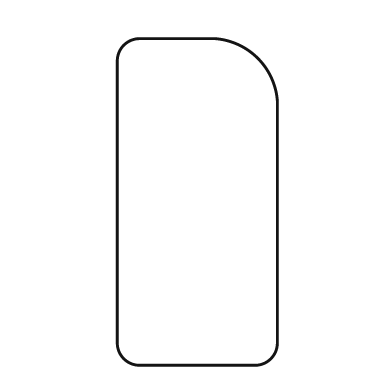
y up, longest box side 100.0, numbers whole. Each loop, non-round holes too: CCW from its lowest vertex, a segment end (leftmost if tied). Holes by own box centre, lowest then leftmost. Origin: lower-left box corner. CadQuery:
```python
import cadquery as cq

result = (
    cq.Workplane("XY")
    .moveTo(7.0, 0.0)
    .lineTo(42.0, 0.0)
    .threePointArc((47.0, 2.0), (49.0, 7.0))
    .lineTo(49.0, 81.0)
    .threePointArc((43.0, 94.0), (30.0, 100.0))
    .lineTo(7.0, 100.0)
    .threePointArc((2.0, 98.0), (0.0, 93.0))
    .lineTo(0.0, 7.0)
    .threePointArc((2.0, 2.0), (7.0, 0.0))
    .close()
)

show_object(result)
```